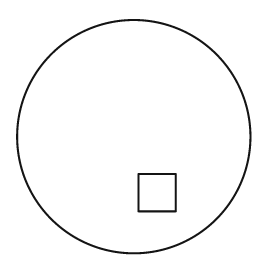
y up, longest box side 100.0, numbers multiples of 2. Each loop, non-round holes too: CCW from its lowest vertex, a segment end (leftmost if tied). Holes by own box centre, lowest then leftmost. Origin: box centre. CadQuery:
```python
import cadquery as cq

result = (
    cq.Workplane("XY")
    .moveTo(0.0, 0.0)
    .circle(50.0)
    .moveTo(2.0, -32.0)
    .lineTo(18.0, -32.0)
    .lineTo(18.0, -16.0)
    .lineTo(2.0, -16.0)
    .close()
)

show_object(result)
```